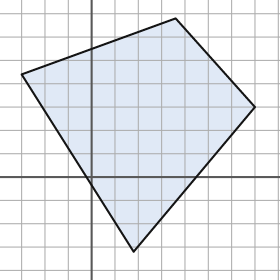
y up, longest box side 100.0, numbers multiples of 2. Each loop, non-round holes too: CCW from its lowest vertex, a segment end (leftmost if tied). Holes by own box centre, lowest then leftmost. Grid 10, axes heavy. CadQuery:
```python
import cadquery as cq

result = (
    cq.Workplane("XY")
    .moveTo(18.0, -32.0)
    .lineTo(70.0, 30.0)
    .lineTo(36.0, 68.0)
    .lineTo(-30.0, 44.0)
    .close()
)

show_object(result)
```